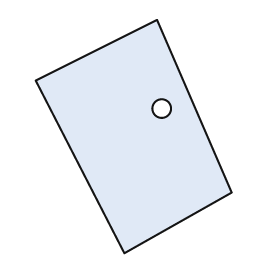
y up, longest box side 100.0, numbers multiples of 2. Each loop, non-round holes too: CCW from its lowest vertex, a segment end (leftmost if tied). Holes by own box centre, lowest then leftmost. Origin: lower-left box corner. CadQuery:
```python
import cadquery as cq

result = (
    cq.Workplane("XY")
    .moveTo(38.0, 0.0)
    .lineTo(84.0, 26.0)
    .lineTo(52.0, 100.0)
    .lineTo(0.0, 74.0)
    .close()
    .moveTo(54.0, 62.0)
    .circle(4.0)
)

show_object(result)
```